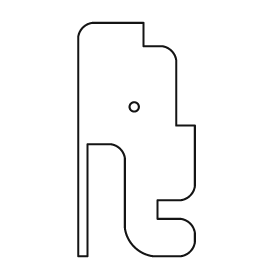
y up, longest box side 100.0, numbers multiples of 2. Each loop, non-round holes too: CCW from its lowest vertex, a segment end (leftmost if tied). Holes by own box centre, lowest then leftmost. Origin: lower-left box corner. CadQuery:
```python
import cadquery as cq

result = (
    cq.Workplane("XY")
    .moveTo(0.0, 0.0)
    .lineTo(4.0, 0.0)
    .lineTo(4.0, 48.0)
    .lineTo(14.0, 48.0)
    .threePointArc((18.0, 46.0), (20.0, 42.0))
    .lineTo(20.0, 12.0)
    .threePointArc((24.0, 4.0), (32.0, 0.0))
    .lineTo(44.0, 0.0)
    .threePointArc((48.0, 2.0), (50.0, 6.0))
    .lineTo(50.0, 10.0)
    .threePointArc((48.0, 14.0), (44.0, 16.0))
    .lineTo(34.0, 16.0)
    .lineTo(34.0, 24.0)
    .lineTo(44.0, 24.0)
    .threePointArc((48.0, 26.0), (50.0, 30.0))
    .lineTo(50.0, 56.0)
    .lineTo(42.0, 56.0)
    .lineTo(42.0, 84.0)
    .threePointArc((40.0, 88.0), (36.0, 90.0))
    .lineTo(28.0, 90.0)
    .lineTo(28.0, 100.0)
    .lineTo(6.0, 100.0)
    .threePointArc((2.0, 98.0), (0.0, 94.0))
    .close()
    .moveTo(24.0, 64.0)
    .circle(2.0)
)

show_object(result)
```